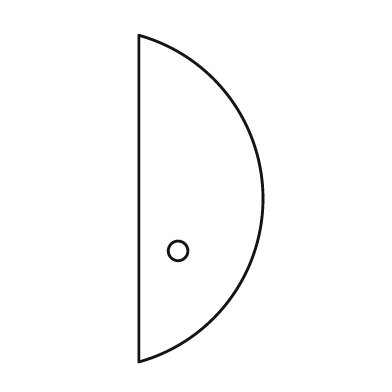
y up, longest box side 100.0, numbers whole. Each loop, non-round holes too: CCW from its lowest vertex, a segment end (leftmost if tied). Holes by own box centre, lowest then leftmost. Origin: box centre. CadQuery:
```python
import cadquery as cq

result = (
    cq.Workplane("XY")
    .moveTo(-19.0, -50.0)
    .threePointArc((19.0, 0.0), (-19.0, 50.0))
    .close()
    .moveTo(-7.0, -16.0)
    .circle(3.0)
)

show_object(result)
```